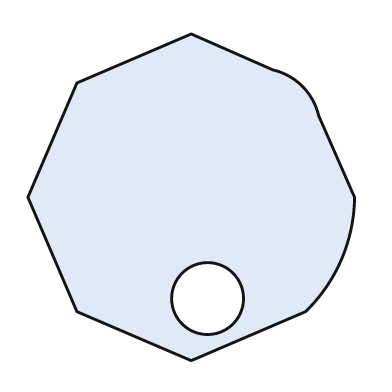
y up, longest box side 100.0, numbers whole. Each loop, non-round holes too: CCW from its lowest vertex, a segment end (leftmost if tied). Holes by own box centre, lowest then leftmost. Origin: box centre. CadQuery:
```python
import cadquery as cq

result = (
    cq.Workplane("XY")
    .moveTo(0.0, -50.0)
    .lineTo(35.0, -35.0)
    .threePointArc((46.0, -19.0), (50.0, 0.0))
    .lineTo(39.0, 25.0)
    .threePointArc((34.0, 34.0), (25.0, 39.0))
    .lineTo(0.0, 50.0)
    .lineTo(-35.0, 35.0)
    .lineTo(-50.0, 0.0)
    .lineTo(-35.0, -35.0)
    .close()
    .moveTo(5.0, -31.0)
    .circle(11.0)
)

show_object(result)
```